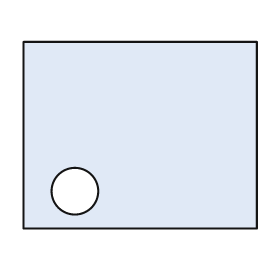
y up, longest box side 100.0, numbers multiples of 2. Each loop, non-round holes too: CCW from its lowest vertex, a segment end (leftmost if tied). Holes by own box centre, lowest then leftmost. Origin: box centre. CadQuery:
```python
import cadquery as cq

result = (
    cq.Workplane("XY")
    .moveTo(-50.0, -40.0)
    .lineTo(50.0, -40.0)
    .lineTo(50.0, 40.0)
    .lineTo(-50.0, 40.0)
    .close()
    .moveTo(-28.0, -24.0)
    .circle(10.0)
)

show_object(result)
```